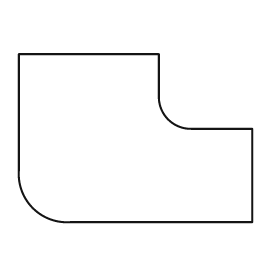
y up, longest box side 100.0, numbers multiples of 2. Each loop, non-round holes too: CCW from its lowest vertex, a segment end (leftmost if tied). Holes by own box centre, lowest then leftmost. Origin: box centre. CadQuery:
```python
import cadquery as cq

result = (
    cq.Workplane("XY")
    .moveTo(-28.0, -36.0)
    .lineTo(50.0, -36.0)
    .lineTo(50.0, 4.0)
    .lineTo(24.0, 4.0)
    .threePointArc((14.0, 8.0), (10.0, 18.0))
    .lineTo(10.0, 36.0)
    .lineTo(-50.0, 36.0)
    .lineTo(-50.0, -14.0)
    .threePointArc((-44.0, -30.0), (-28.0, -36.0))
    .close()
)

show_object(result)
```